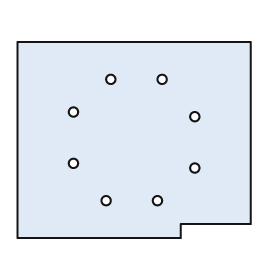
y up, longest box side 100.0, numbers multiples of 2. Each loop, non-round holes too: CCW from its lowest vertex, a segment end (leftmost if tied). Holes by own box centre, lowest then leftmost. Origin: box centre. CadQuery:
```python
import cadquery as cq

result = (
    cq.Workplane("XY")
    .moveTo(-50.0, -42.0)
    .lineTo(20.0, -42.0)
    .lineTo(20.0, -36.0)
    .lineTo(50.0, -36.0)
    .lineTo(50.0, 42.0)
    .lineTo(-50.0, 42.0)
    .close()
    .moveTo(-12.0, -26.0)
    .circle(2.0)
    .moveTo(10.0, -26.0)
    .circle(2.0)
    .moveTo(26.0, -12.0)
    .circle(2.0)
    .moveTo(-26.0, -10.0)
    .circle(2.0)
    .moveTo(26.0, 10.0)
    .circle(2.0)
    .moveTo(-26.0, 12.0)
    .circle(2.0)
    .moveTo(-10.0, 26.0)
    .circle(2.0)
    .moveTo(12.0, 26.0)
    .circle(2.0)
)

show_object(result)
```